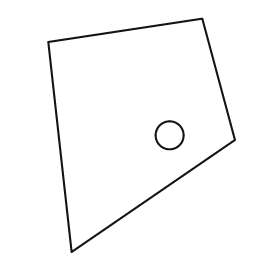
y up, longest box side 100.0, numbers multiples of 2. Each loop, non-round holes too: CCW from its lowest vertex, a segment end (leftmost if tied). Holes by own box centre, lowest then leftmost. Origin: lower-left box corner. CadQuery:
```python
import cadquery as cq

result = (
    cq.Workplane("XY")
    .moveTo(10.0, 0.0)
    .lineTo(80.0, 48.0)
    .lineTo(66.0, 100.0)
    .lineTo(0.0, 90.0)
    .close()
    .moveTo(52.0, 50.0)
    .circle(6.0)
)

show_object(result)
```